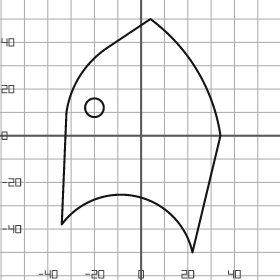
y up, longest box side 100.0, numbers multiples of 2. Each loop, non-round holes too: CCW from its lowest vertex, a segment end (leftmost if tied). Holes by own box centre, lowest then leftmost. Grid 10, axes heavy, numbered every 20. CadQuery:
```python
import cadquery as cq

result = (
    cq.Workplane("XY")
    .moveTo(22.0, -50.0)
    .lineTo(34.0, 0.0)
    .threePointArc((24.0, 28.0), (4.0, 50.0))
    .lineTo(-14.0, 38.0)
    .threePointArc((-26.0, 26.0), (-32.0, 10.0))
    .lineTo(-34.0, -38.0)
    .threePointArc((-2.0, -26.0), (22.0, -50.0))
    .close()
    .moveTo(-20.0, 12.0)
    .circle(4.0)
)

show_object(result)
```